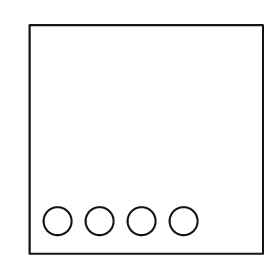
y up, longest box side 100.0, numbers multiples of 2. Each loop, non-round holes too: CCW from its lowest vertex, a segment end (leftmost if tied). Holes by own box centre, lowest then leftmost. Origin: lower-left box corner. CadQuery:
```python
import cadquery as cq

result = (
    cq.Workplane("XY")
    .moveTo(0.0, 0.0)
    .lineTo(100.0, 0.0)
    .lineTo(100.0, 98.0)
    .lineTo(0.0, 98.0)
    .close()
    .moveTo(12.0, 14.0)
    .circle(6.0)
    .moveTo(30.0, 14.0)
    .circle(6.0)
    .moveTo(48.0, 14.0)
    .circle(6.0)
    .moveTo(66.0, 14.0)
    .circle(6.0)
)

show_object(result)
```